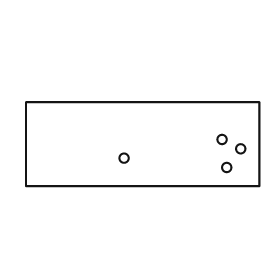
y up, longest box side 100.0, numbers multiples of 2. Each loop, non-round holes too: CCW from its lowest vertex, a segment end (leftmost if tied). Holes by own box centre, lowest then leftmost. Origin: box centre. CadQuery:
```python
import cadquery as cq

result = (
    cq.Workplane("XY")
    .moveTo(-50.0, -18.0)
    .lineTo(50.0, -18.0)
    .lineTo(50.0, 18.0)
    .lineTo(-50.0, 18.0)
    .close()
    .moveTo(36.0, -10.0)
    .circle(2.0)
    .moveTo(-8.0, -6.0)
    .circle(2.0)
    .moveTo(42.0, -2.0)
    .circle(2.0)
    .moveTo(34.0, 2.0)
    .circle(2.0)
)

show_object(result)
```